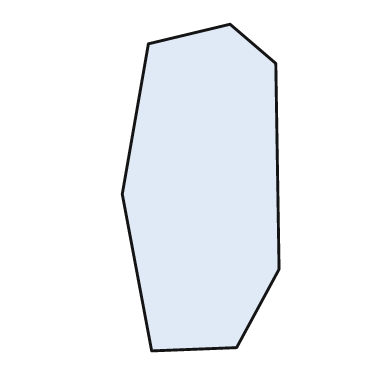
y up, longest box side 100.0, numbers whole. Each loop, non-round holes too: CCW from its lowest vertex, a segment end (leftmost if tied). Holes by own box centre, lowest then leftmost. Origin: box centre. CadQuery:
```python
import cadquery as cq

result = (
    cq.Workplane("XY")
    .moveTo(-15.0, -50.0)
    .lineTo(11.0, -49.0)
    .lineTo(24.0, -25.0)
    .lineTo(23.0, 38.0)
    .lineTo(9.0, 50.0)
    .lineTo(-16.0, 44.0)
    .lineTo(-24.0, -2.0)
    .close()
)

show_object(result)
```